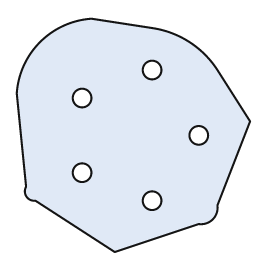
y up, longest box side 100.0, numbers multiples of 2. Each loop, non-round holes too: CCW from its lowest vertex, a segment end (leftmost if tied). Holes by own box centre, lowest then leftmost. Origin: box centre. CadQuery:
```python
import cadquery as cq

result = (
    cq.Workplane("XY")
    .moveTo(-8.0, -50.0)
    .lineTo(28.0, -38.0)
    .threePointArc((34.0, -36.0), (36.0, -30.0))
    .lineTo(50.0, 6.0)
    .lineTo(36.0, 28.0)
    .threePointArc((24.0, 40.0), (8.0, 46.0))
    .lineTo(-18.0, 50.0)
    .threePointArc((-40.0, 40.0), (-50.0, 18.0))
    .lineTo(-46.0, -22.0)
    .threePointArc((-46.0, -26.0), (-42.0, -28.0))
    .close()
    .moveTo(8.0, -28.0)
    .circle(4.0)
    .moveTo(-22.0, -16.0)
    .circle(4.0)
    .moveTo(28.0, 0.0)
    .circle(4.0)
    .moveTo(-22.0, 16.0)
    .circle(4.0)
    .moveTo(8.0, 28.0)
    .circle(4.0)
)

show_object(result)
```